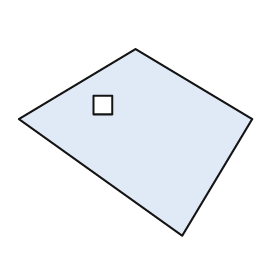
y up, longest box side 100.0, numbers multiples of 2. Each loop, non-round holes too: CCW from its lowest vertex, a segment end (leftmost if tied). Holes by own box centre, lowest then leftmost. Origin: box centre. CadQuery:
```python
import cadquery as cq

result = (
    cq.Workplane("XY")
    .moveTo(20.0, -40.0)
    .lineTo(50.0, 10.0)
    .lineTo(0.0, 40.0)
    .lineTo(-50.0, 10.0)
    .close()
    .moveTo(-18.0, 12.0)
    .lineTo(-10.0, 12.0)
    .lineTo(-10.0, 20.0)
    .lineTo(-18.0, 20.0)
    .close()
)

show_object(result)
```